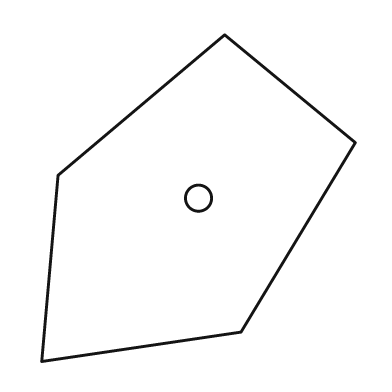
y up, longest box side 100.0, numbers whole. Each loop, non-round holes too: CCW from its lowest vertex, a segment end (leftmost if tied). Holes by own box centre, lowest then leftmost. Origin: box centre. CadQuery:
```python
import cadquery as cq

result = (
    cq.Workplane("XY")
    .moveTo(-48.0, -50.0)
    .lineTo(13.0, -41.0)
    .lineTo(48.0, 17.0)
    .lineTo(8.0, 50.0)
    .lineTo(-43.0, 7.0)
    .close()
    .moveTo(0.0, 0.0)
    .circle(4.0)
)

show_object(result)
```